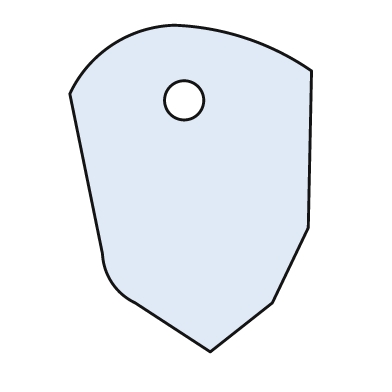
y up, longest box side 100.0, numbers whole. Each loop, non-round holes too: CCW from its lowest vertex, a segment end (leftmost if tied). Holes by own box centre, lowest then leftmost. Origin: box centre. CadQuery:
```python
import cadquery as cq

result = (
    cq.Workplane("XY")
    .moveTo(6.0, -50.0)
    .lineTo(25.0, -35.0)
    .lineTo(36.0, -12.0)
    .lineTo(37.0, 36.0)
    .threePointArc((17.0, 46.0), (-5.0, 50.0))
    .threePointArc((-24.0, 44.0), (-37.0, 29.0))
    .lineTo(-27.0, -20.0)
    .threePointArc((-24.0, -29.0), (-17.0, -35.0))
    .close()
    .moveTo(-2.0, 27.0)
    .circle(6.0)
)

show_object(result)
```